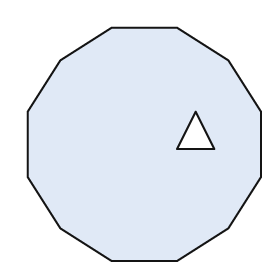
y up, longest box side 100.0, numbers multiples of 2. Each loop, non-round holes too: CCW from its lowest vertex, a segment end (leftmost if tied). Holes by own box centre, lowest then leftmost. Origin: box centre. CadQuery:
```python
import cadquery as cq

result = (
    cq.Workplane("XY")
    .moveTo(-14.0, -50.0)
    .lineTo(14.0, -50.0)
    .lineTo(36.0, -36.0)
    .lineTo(50.0, -14.0)
    .lineTo(50.0, 14.0)
    .lineTo(36.0, 36.0)
    .lineTo(14.0, 50.0)
    .lineTo(-14.0, 50.0)
    .lineTo(-36.0, 36.0)
    .lineTo(-50.0, 14.0)
    .lineTo(-50.0, -14.0)
    .lineTo(-36.0, -36.0)
    .close()
    .moveTo(14.0, -2.0)
    .lineTo(30.0, -2.0)
    .lineTo(22.0, 14.0)
    .close()
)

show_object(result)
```